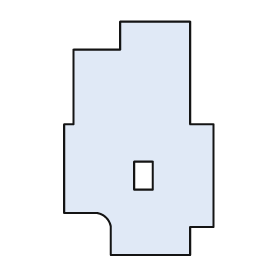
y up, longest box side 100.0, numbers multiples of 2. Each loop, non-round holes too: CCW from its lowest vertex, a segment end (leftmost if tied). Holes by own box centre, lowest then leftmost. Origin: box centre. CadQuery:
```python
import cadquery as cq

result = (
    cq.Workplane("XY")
    .moveTo(-12.0, -50.0)
    .lineTo(22.0, -50.0)
    .lineTo(22.0, -38.0)
    .lineTo(32.0, -38.0)
    .lineTo(32.0, 6.0)
    .lineTo(22.0, 6.0)
    .lineTo(22.0, 50.0)
    .lineTo(-8.0, 50.0)
    .lineTo(-8.0, 38.0)
    .lineTo(-28.0, 38.0)
    .lineTo(-28.0, 6.0)
    .lineTo(-32.0, 6.0)
    .lineTo(-32.0, -32.0)
    .lineTo(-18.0, -32.0)
    .threePointArc((-14.0, -34.0), (-12.0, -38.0))
    .close()
    .moveTo(-2.0, -22.0)
    .lineTo(6.0, -22.0)
    .lineTo(6.0, -10.0)
    .lineTo(-2.0, -10.0)
    .close()
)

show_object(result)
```